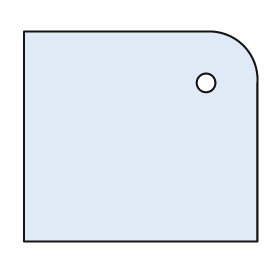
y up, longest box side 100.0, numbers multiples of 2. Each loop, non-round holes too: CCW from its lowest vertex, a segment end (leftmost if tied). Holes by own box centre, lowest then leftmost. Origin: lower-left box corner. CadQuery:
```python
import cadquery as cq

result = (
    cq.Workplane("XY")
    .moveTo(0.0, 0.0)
    .lineTo(100.0, 0.0)
    .lineTo(100.0, 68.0)
    .threePointArc((94.0, 84.0), (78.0, 90.0))
    .lineTo(0.0, 90.0)
    .close()
    .moveTo(78.0, 68.0)
    .circle(4.0)
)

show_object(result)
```